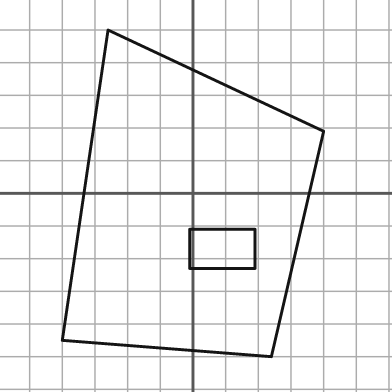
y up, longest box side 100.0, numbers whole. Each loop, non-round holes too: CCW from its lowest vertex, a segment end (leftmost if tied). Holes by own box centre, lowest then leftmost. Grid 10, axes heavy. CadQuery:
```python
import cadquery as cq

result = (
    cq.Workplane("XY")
    .moveTo(24.0, -50.0)
    .lineTo(40.0, 19.0)
    .lineTo(-26.0, 50.0)
    .lineTo(-40.0, -45.0)
    .close()
    .moveTo(-1.0, -23.0)
    .lineTo(19.0, -23.0)
    .lineTo(19.0, -11.0)
    .lineTo(-1.0, -11.0)
    .close()
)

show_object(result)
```